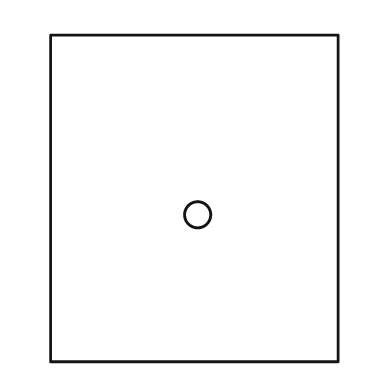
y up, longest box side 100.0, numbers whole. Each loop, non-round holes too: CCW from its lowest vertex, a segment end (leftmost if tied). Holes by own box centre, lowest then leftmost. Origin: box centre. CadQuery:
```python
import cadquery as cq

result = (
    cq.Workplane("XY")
    .moveTo(-44.0, -50.0)
    .lineTo(44.0, -50.0)
    .lineTo(44.0, 50.0)
    .lineTo(-44.0, 50.0)
    .close()
    .moveTo(1.0, -5.0)
    .circle(4.0)
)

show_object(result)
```